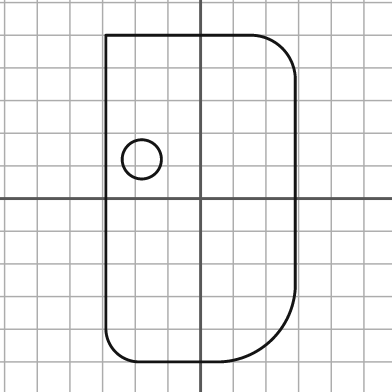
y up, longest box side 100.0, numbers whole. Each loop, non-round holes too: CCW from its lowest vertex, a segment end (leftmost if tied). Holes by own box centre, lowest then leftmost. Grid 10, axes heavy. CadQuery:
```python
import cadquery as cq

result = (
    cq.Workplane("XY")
    .moveTo(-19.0, -50.0)
    .lineTo(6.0, -50.0)
    .threePointArc((22.0, -43.0), (29.0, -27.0))
    .lineTo(29.0, 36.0)
    .threePointArc((25.0, 46.0), (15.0, 50.0))
    .lineTo(-29.0, 50.0)
    .lineTo(-29.0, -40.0)
    .threePointArc((-26.0, -47.0), (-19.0, -50.0))
    .close()
    .moveTo(-18.0, 12.0)
    .circle(6.0)
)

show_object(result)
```